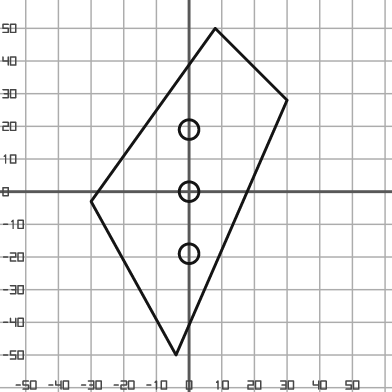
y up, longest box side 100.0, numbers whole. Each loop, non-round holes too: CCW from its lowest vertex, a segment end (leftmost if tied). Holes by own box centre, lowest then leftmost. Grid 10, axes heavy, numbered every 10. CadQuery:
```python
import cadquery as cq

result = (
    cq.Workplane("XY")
    .moveTo(-4.0, -50.0)
    .lineTo(30.0, 28.0)
    .lineTo(8.0, 50.0)
    .lineTo(-30.0, -3.0)
    .close()
    .moveTo(0.0, -19.0)
    .circle(3.0)
    .moveTo(0.0, 0.0)
    .circle(3.0)
    .moveTo(0.0, 19.0)
    .circle(3.0)
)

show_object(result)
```